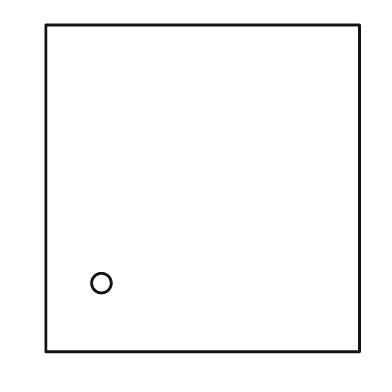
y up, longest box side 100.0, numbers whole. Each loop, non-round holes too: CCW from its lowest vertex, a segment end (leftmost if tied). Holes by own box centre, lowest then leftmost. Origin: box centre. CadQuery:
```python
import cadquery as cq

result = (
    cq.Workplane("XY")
    .moveTo(-48.0, -50.0)
    .lineTo(48.0, -50.0)
    .lineTo(48.0, 50.0)
    .lineTo(-48.0, 50.0)
    .close()
    .moveTo(-31.0, -29.0)
    .circle(3.0)
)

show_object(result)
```